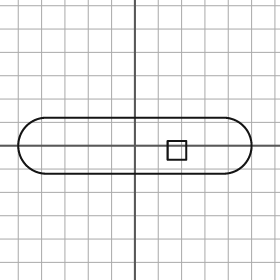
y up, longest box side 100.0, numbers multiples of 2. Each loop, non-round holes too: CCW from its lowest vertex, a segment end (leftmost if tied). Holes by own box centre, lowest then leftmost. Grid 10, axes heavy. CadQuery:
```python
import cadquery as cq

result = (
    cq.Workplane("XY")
    .moveTo(-38.0, -12.0)
    .lineTo(38.0, -12.0)
    .threePointArc((50.0, 0.0), (38.0, 12.0))
    .lineTo(-38.0, 12.0)
    .threePointArc((-50.0, 0.0), (-38.0, -12.0))
    .close()
    .moveTo(14.0, -6.0)
    .lineTo(22.0, -6.0)
    .lineTo(22.0, 2.0)
    .lineTo(14.0, 2.0)
    .close()
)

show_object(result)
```